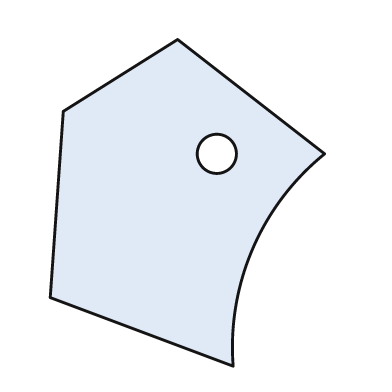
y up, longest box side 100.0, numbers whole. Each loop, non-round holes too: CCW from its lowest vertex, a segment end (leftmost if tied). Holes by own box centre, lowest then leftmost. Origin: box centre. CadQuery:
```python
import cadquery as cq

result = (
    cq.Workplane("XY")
    .moveTo(14.0, -50.0)
    .threePointArc((20.0, -14.0), (42.0, 15.0))
    .lineTo(-3.0, 50.0)
    .lineTo(-38.0, 28.0)
    .lineTo(-42.0, -29.0)
    .close()
    .moveTo(9.0, 15.0)
    .circle(6.0)
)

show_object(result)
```